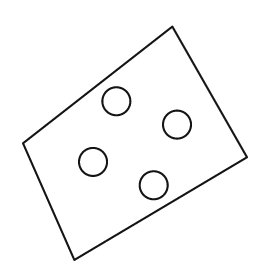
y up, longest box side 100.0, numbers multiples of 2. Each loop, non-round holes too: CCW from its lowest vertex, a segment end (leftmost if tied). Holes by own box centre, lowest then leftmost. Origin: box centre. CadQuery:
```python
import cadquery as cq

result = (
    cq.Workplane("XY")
    .moveTo(-26.0, -50.0)
    .lineTo(48.0, -6.0)
    .lineTo(16.0, 50.0)
    .lineTo(-48.0, 0.0)
    .close()
    .moveTo(8.0, -18.0)
    .circle(6.0)
    .moveTo(-18.0, -8.0)
    .circle(6.0)
    .moveTo(18.0, 8.0)
    .circle(6.0)
    .moveTo(-8.0, 18.0)
    .circle(6.0)
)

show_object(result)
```